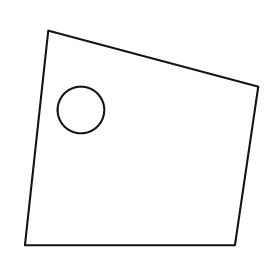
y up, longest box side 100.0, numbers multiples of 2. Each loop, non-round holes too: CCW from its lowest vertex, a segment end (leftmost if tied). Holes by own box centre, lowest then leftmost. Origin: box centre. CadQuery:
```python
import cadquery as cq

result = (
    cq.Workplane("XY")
    .moveTo(-50.0, -46.0)
    .lineTo(40.0, -46.0)
    .lineTo(50.0, 22.0)
    .lineTo(-40.0, 46.0)
    .close()
    .moveTo(-26.0, 12.0)
    .circle(10.0)
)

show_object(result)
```